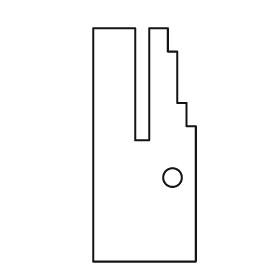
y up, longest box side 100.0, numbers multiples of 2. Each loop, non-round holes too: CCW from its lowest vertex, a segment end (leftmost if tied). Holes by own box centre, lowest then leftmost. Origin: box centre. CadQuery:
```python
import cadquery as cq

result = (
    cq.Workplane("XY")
    .moveTo(-22.0, -50.0)
    .lineTo(22.0, -50.0)
    .lineTo(22.0, 8.0)
    .lineTo(18.0, 8.0)
    .lineTo(18.0, 18.0)
    .lineTo(14.0, 18.0)
    .lineTo(14.0, 40.0)
    .lineTo(10.0, 40.0)
    .lineTo(10.0, 50.0)
    .lineTo(2.0, 50.0)
    .lineTo(2.0, 2.0)
    .lineTo(-4.0, 2.0)
    .lineTo(-4.0, 50.0)
    .lineTo(-22.0, 50.0)
    .close()
    .moveTo(12.0, -14.0)
    .circle(4.0)
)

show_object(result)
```